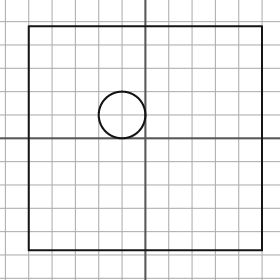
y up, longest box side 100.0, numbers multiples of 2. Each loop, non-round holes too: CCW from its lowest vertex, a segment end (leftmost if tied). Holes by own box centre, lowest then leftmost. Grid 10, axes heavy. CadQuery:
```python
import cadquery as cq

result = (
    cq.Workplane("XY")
    .moveTo(-50.0, -48.0)
    .lineTo(50.0, -48.0)
    .lineTo(50.0, 48.0)
    .lineTo(-50.0, 48.0)
    .close()
    .moveTo(-10.0, 10.0)
    .circle(10.0)
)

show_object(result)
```